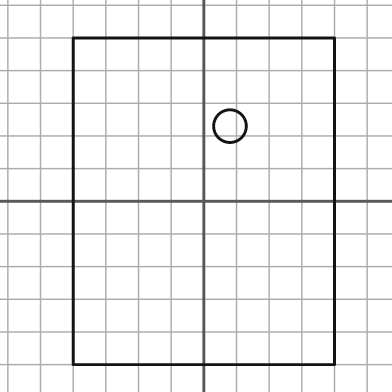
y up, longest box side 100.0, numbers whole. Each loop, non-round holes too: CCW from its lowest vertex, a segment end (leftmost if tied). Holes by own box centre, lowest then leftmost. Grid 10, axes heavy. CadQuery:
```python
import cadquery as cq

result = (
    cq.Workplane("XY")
    .moveTo(-40.0, -50.0)
    .lineTo(40.0, -50.0)
    .lineTo(40.0, 50.0)
    .lineTo(-40.0, 50.0)
    .close()
    .moveTo(8.0, 23.0)
    .circle(5.0)
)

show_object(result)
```